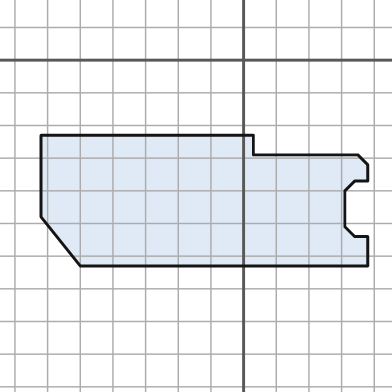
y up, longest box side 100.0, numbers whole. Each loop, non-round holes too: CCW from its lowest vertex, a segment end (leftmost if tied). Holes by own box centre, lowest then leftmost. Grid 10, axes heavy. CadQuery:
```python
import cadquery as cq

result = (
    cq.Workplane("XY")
    .moveTo(-50.0, -63.0)
    .lineTo(38.0, -63.0)
    .lineTo(38.0, -54.0)
    .lineTo(34.0, -54.0)
    .lineTo(31.0, -51.0)
    .lineTo(31.0, -40.0)
    .lineTo(34.0, -37.0)
    .lineTo(38.0, -37.0)
    .lineTo(38.0, -32.0)
    .lineTo(35.0, -29.0)
    .lineTo(3.0, -29.0)
    .lineTo(3.0, -23.0)
    .lineTo(-62.0, -23.0)
    .lineTo(-62.0, -48.0)
    .close()
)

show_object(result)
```